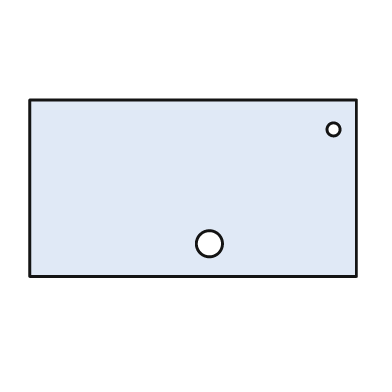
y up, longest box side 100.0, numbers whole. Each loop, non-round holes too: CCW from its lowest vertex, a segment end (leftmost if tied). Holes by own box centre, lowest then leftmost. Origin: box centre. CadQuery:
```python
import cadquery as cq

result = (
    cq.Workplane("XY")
    .moveTo(-50.0, -27.0)
    .lineTo(50.0, -27.0)
    .lineTo(50.0, 27.0)
    .lineTo(-50.0, 27.0)
    .close()
    .moveTo(5.0, -17.0)
    .circle(4.0)
    .moveTo(43.0, 18.0)
    .circle(2.0)
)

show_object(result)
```